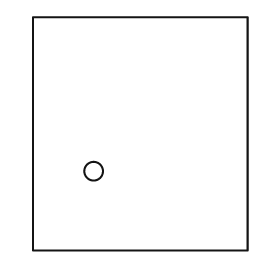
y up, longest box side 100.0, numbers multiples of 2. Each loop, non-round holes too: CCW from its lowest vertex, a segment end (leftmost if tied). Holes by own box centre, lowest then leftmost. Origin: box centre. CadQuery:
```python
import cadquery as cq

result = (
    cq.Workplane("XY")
    .moveTo(-46.0, -50.0)
    .lineTo(46.0, -50.0)
    .lineTo(46.0, 50.0)
    .lineTo(-46.0, 50.0)
    .close()
    .moveTo(-20.0, -16.0)
    .circle(4.0)
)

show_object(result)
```